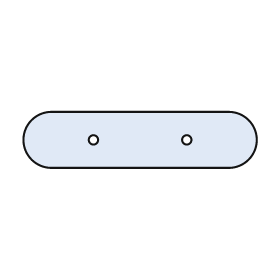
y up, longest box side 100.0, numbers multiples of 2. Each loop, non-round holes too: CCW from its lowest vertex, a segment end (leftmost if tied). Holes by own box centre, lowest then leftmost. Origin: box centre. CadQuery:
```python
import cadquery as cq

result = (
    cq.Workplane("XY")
    .moveTo(-38.0, -12.0)
    .lineTo(38.0, -12.0)
    .threePointArc((50.0, 0.0), (38.0, 12.0))
    .lineTo(-38.0, 12.0)
    .threePointArc((-50.0, 0.0), (-38.0, -12.0))
    .close()
    .moveTo(-20.0, 0.0)
    .circle(2.0)
    .moveTo(20.0, 0.0)
    .circle(2.0)
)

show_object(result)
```